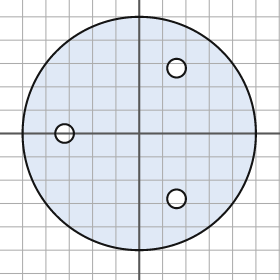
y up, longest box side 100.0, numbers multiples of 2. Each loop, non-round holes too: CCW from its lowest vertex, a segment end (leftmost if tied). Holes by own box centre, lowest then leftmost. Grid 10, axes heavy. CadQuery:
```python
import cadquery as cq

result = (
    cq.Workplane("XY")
    .moveTo(0.0, 0.0)
    .circle(50.0)
    .moveTo(16.0, -28.0)
    .circle(4.0)
    .moveTo(-32.0, 0.0)
    .circle(4.0)
    .moveTo(16.0, 28.0)
    .circle(4.0)
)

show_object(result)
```